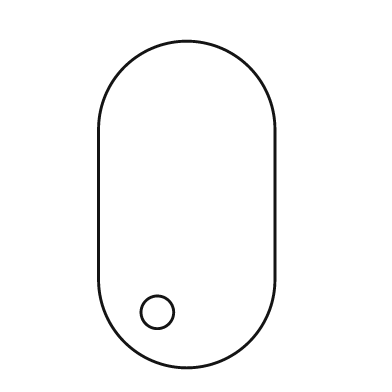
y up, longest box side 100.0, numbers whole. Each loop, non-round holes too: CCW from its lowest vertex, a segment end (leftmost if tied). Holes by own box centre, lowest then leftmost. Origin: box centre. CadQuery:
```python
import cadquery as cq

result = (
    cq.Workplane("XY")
    .moveTo(-27.0, -23.0)
    .threePointArc((0.0, -50.0), (27.0, -23.0))
    .lineTo(27.0, 23.0)
    .threePointArc((0.0, 50.0), (-27.0, 23.0))
    .close()
    .moveTo(-9.0, -33.0)
    .circle(5.0)
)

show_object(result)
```